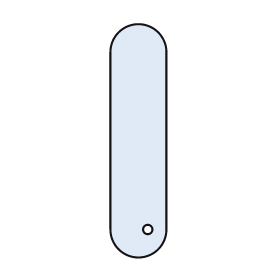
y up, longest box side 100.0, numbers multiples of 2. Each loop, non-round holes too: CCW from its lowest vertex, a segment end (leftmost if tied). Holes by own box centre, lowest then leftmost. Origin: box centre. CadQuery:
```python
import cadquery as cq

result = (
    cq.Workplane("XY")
    .moveTo(-12.0, -38.0)
    .threePointArc((0.0, -50.0), (12.0, -38.0))
    .lineTo(12.0, 38.0)
    .threePointArc((0.0, 50.0), (-12.0, 38.0))
    .close()
    .moveTo(4.0, -38.0)
    .circle(2.0)
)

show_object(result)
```